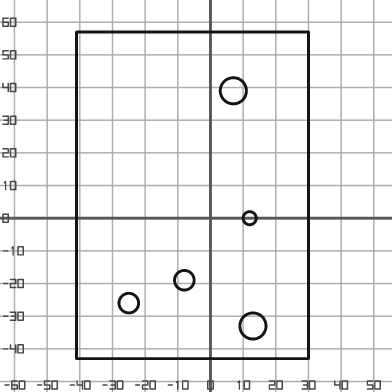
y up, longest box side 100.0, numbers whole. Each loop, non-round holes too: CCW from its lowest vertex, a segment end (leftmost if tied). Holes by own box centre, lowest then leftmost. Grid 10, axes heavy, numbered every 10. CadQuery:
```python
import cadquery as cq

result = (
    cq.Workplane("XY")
    .moveTo(-41.0, -43.0)
    .lineTo(30.0, -43.0)
    .lineTo(30.0, 57.0)
    .lineTo(-41.0, 57.0)
    .close()
    .moveTo(13.0, -33.0)
    .circle(4.0)
    .moveTo(-25.0, -26.0)
    .circle(3.0)
    .moveTo(-8.0, -19.0)
    .circle(3.0)
    .moveTo(12.0, 0.0)
    .circle(2.0)
    .moveTo(7.0, 39.0)
    .circle(4.0)
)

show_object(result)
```